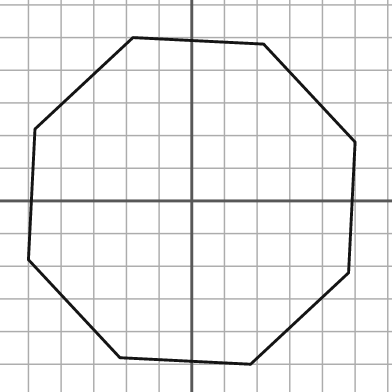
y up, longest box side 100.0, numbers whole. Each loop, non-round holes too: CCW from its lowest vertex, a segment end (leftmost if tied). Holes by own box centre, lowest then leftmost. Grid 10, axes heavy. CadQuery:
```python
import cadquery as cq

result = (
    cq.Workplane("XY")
    .moveTo(18.0, -50.0)
    .lineTo(48.0, -22.0)
    .lineTo(50.0, 18.0)
    .lineTo(22.0, 48.0)
    .lineTo(-18.0, 50.0)
    .lineTo(-48.0, 22.0)
    .lineTo(-50.0, -18.0)
    .lineTo(-22.0, -48.0)
    .close()
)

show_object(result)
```